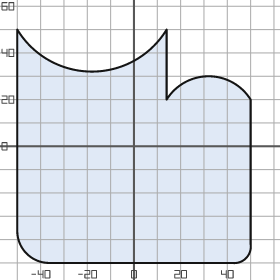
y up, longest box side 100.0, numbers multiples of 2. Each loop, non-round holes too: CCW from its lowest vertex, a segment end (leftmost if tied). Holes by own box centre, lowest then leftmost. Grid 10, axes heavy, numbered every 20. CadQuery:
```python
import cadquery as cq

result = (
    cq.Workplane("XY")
    .moveTo(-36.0, -50.0)
    .lineTo(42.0, -50.0)
    .threePointArc((48.0, -48.0), (50.0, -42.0))
    .lineTo(50.0, 20.0)
    .threePointArc((32.0, 30.0), (14.0, 20.0))
    .lineTo(14.0, 50.0)
    .threePointArc((-18.0, 32.0), (-50.0, 50.0))
    .lineTo(-50.0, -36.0)
    .threePointArc((-46.0, -46.0), (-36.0, -50.0))
    .close()
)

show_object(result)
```